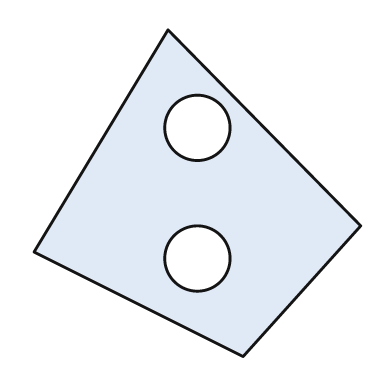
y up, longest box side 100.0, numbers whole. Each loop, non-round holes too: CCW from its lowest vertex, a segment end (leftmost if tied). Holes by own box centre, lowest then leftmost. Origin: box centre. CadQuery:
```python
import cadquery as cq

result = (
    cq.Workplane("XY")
    .moveTo(14.0, -50.0)
    .lineTo(50.0, -10.0)
    .lineTo(-9.0, 50.0)
    .lineTo(-50.0, -18.0)
    .close()
    .moveTo(0.0, -20.0)
    .circle(10.0)
    .moveTo(0.0, 20.0)
    .circle(10.0)
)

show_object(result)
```